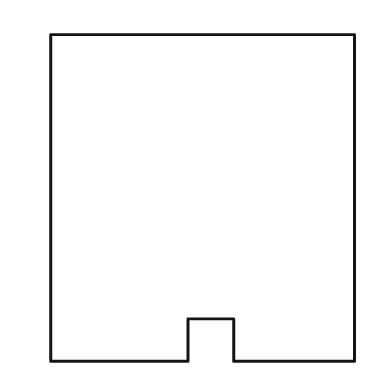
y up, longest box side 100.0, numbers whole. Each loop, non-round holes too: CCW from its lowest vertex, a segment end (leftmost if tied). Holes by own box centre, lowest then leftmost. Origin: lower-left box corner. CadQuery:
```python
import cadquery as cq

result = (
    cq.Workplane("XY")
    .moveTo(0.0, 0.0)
    .lineTo(42.0, 0.0)
    .lineTo(42.0, 13.0)
    .lineTo(56.0, 13.0)
    .lineTo(56.0, 0.0)
    .lineTo(93.0, 0.0)
    .lineTo(93.0, 100.0)
    .lineTo(0.0, 100.0)
    .close()
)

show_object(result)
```